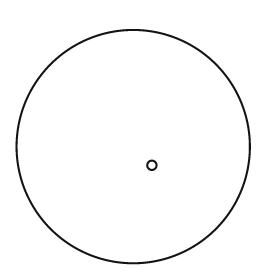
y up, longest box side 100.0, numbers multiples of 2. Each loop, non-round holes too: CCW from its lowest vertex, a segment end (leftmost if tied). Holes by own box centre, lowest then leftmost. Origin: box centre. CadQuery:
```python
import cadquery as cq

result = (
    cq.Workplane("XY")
    .moveTo(0.0, 0.0)
    .circle(50.0)
    .moveTo(8.0, -8.0)
    .circle(2.0)
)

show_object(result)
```